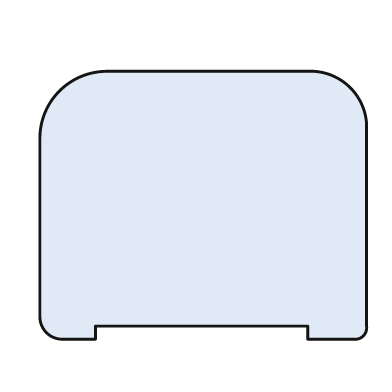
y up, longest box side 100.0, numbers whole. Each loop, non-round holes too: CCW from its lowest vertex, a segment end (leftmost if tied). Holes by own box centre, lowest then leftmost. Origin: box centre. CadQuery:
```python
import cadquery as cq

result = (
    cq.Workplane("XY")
    .moveTo(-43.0, -41.0)
    .lineTo(-33.0, -41.0)
    .lineTo(-33.0, -37.0)
    .lineTo(32.0, -37.0)
    .lineTo(32.0, -41.0)
    .lineTo(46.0, -41.0)
    .threePointArc((49.0, -40.0), (50.0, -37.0))
    .lineTo(50.0, 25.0)
    .threePointArc((45.0, 36.0), (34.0, 41.0))
    .lineTo(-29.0, 41.0)
    .threePointArc((-44.0, 35.0), (-50.0, 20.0))
    .lineTo(-50.0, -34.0)
    .threePointArc((-48.0, -39.0), (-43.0, -41.0))
    .close()
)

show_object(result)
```